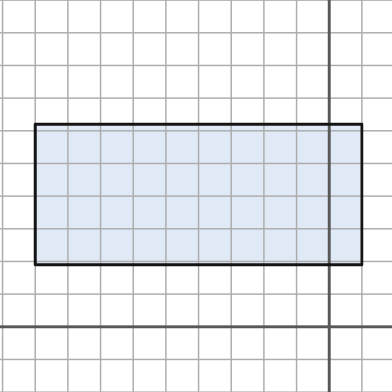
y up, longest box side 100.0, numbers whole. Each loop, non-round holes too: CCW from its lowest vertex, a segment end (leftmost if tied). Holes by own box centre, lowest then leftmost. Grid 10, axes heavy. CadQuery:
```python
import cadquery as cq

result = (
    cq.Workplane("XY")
    .moveTo(-90.0, 19.0)
    .lineTo(10.0, 19.0)
    .lineTo(10.0, 62.0)
    .lineTo(-90.0, 62.0)
    .close()
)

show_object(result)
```